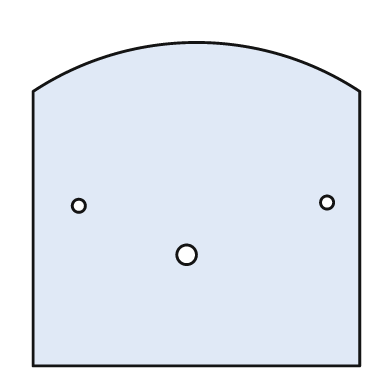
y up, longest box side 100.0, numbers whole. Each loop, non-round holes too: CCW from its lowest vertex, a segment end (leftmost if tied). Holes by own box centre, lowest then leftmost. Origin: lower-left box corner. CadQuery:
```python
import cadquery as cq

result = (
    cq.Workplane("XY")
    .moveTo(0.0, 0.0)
    .lineTo(100.0, 0.0)
    .lineTo(100.0, 84.0)
    .threePointArc((50.0, 99.0), (0.0, 84.0))
    .close()
    .moveTo(47.0, 34.0)
    .circle(3.0)
    .moveTo(14.0, 49.0)
    .circle(2.0)
    .moveTo(90.0, 50.0)
    .circle(2.0)
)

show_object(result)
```